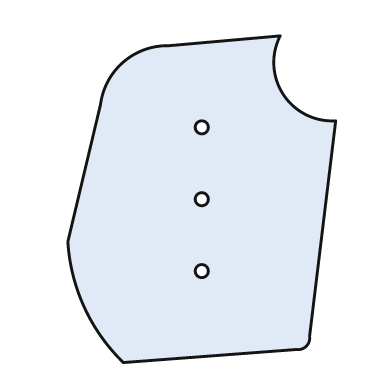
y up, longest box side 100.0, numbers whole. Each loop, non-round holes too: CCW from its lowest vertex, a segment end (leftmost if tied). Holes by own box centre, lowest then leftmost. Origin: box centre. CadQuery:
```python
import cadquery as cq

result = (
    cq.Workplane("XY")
    .moveTo(-24.0, -50.0)
    .lineTo(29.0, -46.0)
    .threePointArc((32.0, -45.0), (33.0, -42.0))
    .lineTo(41.0, 24.0)
    .threePointArc((25.0, 32.0), (24.0, 50.0))
    .lineTo(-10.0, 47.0)
    .threePointArc((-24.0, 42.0), (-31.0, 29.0))
    .lineTo(-41.0, -13.0)
    .threePointArc((-36.0, -33.0), (-24.0, -50.0))
    .close()
    .moveTo(0.0, -22.0)
    .circle(2.0)
    .moveTo(0.0, 0.0)
    .circle(2.0)
    .moveTo(0.0, 22.0)
    .circle(2.0)
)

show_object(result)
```